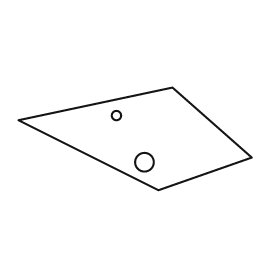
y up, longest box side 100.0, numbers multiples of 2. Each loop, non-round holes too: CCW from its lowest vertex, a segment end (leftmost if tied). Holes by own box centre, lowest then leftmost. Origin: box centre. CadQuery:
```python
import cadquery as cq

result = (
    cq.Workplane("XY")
    .moveTo(10.0, -22.0)
    .lineTo(50.0, -8.0)
    .lineTo(16.0, 22.0)
    .lineTo(-50.0, 8.0)
    .close()
    .moveTo(4.0, -10.0)
    .circle(4.0)
    .moveTo(-8.0, 10.0)
    .circle(2.0)
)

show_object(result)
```